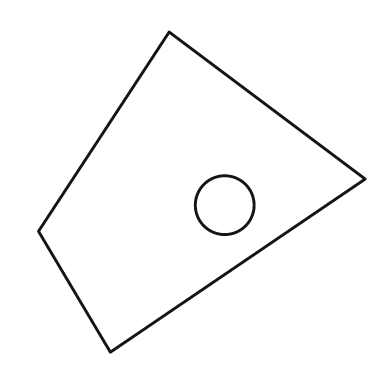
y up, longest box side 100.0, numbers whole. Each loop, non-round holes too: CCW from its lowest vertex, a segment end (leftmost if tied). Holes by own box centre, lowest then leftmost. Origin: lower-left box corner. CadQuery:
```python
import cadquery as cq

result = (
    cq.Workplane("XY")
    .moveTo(22.0, 0.0)
    .lineTo(100.0, 53.0)
    .lineTo(40.0, 98.0)
    .lineTo(0.0, 37.0)
    .close()
    .moveTo(57.0, 45.0)
    .circle(9.0)
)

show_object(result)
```